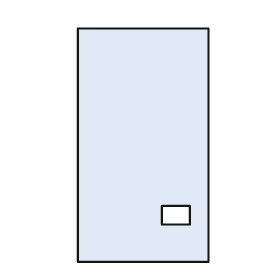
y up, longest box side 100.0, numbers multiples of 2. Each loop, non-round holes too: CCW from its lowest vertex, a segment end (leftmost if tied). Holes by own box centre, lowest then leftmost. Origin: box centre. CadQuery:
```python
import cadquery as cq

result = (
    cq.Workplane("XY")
    .moveTo(-28.0, -50.0)
    .lineTo(28.0, -50.0)
    .lineTo(28.0, 50.0)
    .lineTo(-28.0, 50.0)
    .close()
    .moveTo(8.0, -34.0)
    .lineTo(20.0, -34.0)
    .lineTo(20.0, -26.0)
    .lineTo(8.0, -26.0)
    .close()
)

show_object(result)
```